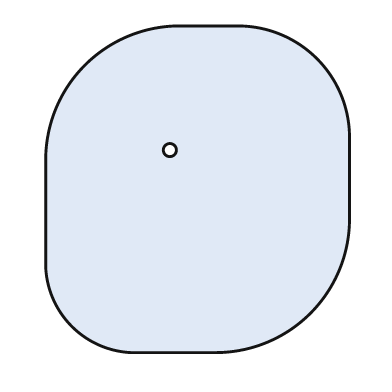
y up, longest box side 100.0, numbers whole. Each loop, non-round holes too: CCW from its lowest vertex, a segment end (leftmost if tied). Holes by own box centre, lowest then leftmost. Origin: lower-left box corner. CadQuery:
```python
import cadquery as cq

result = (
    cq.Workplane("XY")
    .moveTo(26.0, 0.0)
    .lineTo(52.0, 0.0)
    .threePointArc((81.0, 12.0), (93.0, 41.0))
    .lineTo(93.0, 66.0)
    .threePointArc((83.0, 90.0), (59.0, 100.0))
    .lineTo(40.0, 100.0)
    .threePointArc((12.0, 88.0), (0.0, 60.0))
    .lineTo(0.0, 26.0)
    .threePointArc((8.0, 8.0), (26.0, 0.0))
    .close()
    .moveTo(38.0, 62.0)
    .circle(2.0)
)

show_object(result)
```